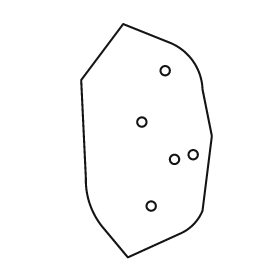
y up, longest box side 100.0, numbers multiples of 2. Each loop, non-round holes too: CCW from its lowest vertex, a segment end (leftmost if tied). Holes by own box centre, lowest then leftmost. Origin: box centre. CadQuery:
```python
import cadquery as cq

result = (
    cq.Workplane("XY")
    .moveTo(-8.0, -50.0)
    .lineTo(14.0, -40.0)
    .threePointArc((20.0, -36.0), (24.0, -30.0))
    .lineTo(28.0, 2.0)
    .lineTo(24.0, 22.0)
    .threePointArc((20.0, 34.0), (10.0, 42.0))
    .lineTo(-10.0, 50.0)
    .lineTo(-28.0, 26.0)
    .lineTo(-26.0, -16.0)
    .threePointArc((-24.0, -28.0), (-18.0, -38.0))
    .close()
    .moveTo(2.0, -28.0)
    .circle(2.0)
    .moveTo(12.0, -8.0)
    .circle(2.0)
    .moveTo(20.0, -6.0)
    .circle(2.0)
    .moveTo(-2.0, 8.0)
    .circle(2.0)
    .moveTo(8.0, 30.0)
    .circle(2.0)
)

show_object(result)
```